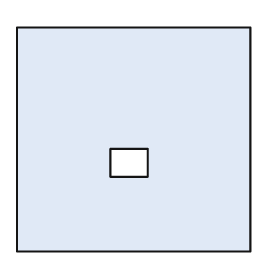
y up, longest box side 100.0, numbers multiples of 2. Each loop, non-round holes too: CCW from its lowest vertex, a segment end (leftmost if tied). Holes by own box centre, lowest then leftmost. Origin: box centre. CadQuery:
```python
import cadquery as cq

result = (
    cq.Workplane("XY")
    .moveTo(-50.0, -48.0)
    .lineTo(50.0, -48.0)
    .lineTo(50.0, 48.0)
    .lineTo(-50.0, 48.0)
    .close()
    .moveTo(-10.0, -16.0)
    .lineTo(6.0, -16.0)
    .lineTo(6.0, -4.0)
    .lineTo(-10.0, -4.0)
    .close()
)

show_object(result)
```